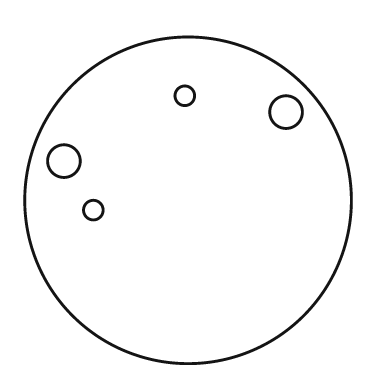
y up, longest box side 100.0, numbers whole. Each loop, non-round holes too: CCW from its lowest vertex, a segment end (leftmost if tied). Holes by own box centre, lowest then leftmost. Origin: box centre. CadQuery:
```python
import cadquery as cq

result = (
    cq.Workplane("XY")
    .moveTo(0.0, 0.0)
    .circle(50.0)
    .moveTo(-29.0, -3.0)
    .circle(3.0)
    .moveTo(-38.0, 12.0)
    .circle(5.0)
    .moveTo(30.0, 27.0)
    .circle(5.0)
    .moveTo(-1.0, 32.0)
    .circle(3.0)
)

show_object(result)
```